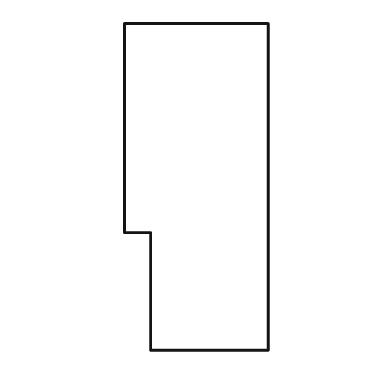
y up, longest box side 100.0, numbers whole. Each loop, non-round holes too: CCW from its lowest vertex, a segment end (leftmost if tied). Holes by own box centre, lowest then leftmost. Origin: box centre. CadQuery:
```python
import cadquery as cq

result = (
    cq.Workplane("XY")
    .moveTo(-14.0, -50.0)
    .lineTo(22.0, -50.0)
    .lineTo(22.0, 50.0)
    .lineTo(-22.0, 50.0)
    .lineTo(-22.0, -14.0)
    .lineTo(-14.0, -14.0)
    .close()
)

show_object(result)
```